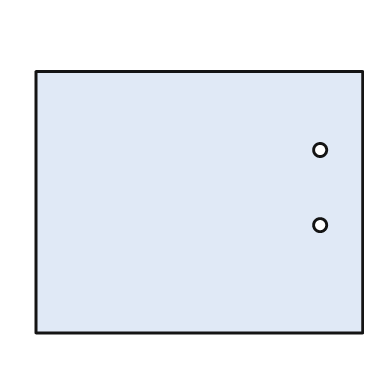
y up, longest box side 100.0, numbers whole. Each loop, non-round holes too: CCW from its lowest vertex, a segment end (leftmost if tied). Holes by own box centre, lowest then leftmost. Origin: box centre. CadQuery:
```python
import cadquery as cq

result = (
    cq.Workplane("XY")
    .moveTo(-50.0, -40.0)
    .lineTo(50.0, -40.0)
    .lineTo(50.0, 40.0)
    .lineTo(-50.0, 40.0)
    .close()
    .moveTo(37.0, -7.0)
    .circle(2.0)
    .moveTo(37.0, 16.0)
    .circle(2.0)
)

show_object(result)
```